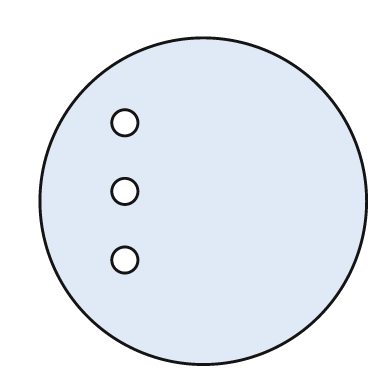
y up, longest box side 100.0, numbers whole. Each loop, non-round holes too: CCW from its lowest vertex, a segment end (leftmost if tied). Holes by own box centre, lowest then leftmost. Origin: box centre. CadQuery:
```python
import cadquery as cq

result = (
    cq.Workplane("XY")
    .moveTo(0.0, 0.0)
    .circle(50.0)
    .moveTo(-24.0, -18.0)
    .circle(4.0)
    .moveTo(-24.0, 3.0)
    .circle(4.0)
    .moveTo(-24.0, 24.0)
    .circle(4.0)
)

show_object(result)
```